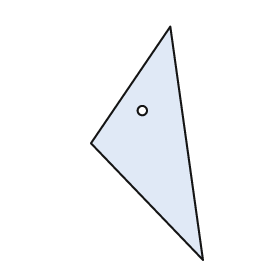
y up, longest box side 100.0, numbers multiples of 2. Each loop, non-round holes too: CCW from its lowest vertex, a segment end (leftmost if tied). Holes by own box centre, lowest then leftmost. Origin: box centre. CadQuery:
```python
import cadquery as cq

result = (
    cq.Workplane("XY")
    .moveTo(24.0, -50.0)
    .lineTo(10.0, 50.0)
    .lineTo(-24.0, 0.0)
    .close()
    .moveTo(-2.0, 14.0)
    .circle(2.0)
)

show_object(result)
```